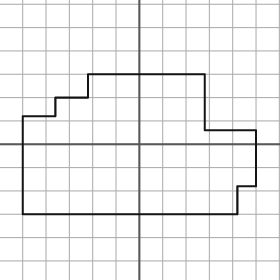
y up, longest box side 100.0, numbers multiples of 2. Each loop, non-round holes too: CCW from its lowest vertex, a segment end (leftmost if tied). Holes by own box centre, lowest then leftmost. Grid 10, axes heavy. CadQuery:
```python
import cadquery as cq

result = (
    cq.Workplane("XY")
    .moveTo(-50.0, -30.0)
    .lineTo(42.0, -30.0)
    .lineTo(42.0, -18.0)
    .lineTo(50.0, -18.0)
    .lineTo(50.0, 6.0)
    .lineTo(28.0, 6.0)
    .lineTo(28.0, 30.0)
    .lineTo(-22.0, 30.0)
    .lineTo(-22.0, 20.0)
    .lineTo(-36.0, 20.0)
    .lineTo(-36.0, 12.0)
    .lineTo(-50.0, 12.0)
    .close()
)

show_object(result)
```